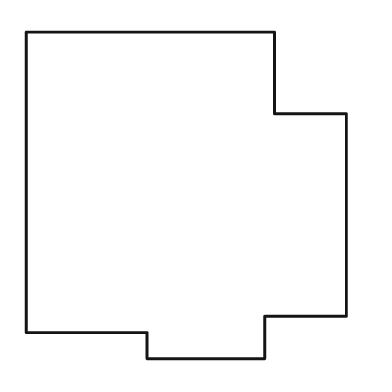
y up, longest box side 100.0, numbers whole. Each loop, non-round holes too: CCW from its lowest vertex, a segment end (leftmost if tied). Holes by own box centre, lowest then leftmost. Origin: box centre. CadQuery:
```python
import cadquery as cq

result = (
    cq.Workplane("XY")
    .moveTo(-12.0, -50.0)
    .lineTo(24.0, -50.0)
    .lineTo(24.0, -37.0)
    .lineTo(49.0, -37.0)
    .lineTo(49.0, 25.0)
    .lineTo(27.0, 25.0)
    .lineTo(27.0, 50.0)
    .lineTo(-49.0, 50.0)
    .lineTo(-49.0, -42.0)
    .lineTo(-12.0, -42.0)
    .close()
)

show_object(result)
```